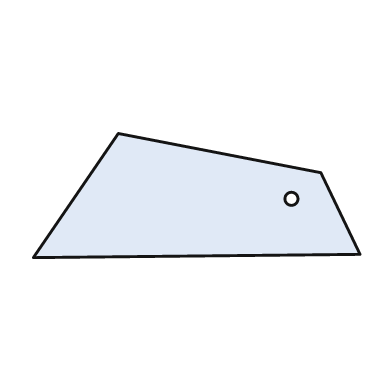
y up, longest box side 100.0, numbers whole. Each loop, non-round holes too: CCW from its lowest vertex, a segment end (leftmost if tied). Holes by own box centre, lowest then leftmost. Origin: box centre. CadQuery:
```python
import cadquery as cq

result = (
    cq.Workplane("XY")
    .moveTo(-50.0, -19.0)
    .lineTo(50.0, -18.0)
    .lineTo(38.0, 7.0)
    .lineTo(-24.0, 19.0)
    .close()
    .moveTo(29.0, -1.0)
    .circle(2.0)
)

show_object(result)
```